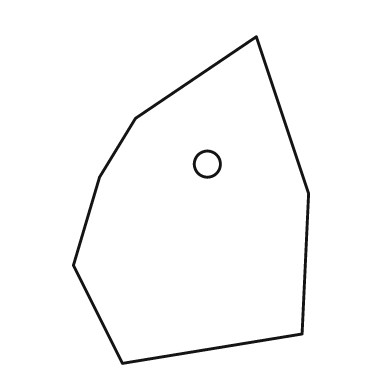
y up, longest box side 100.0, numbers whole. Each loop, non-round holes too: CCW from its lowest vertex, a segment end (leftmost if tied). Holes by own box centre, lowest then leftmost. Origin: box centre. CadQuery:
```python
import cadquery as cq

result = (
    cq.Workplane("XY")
    .moveTo(-21.0, -50.0)
    .lineTo(34.0, -41.0)
    .lineTo(36.0, 2.0)
    .lineTo(20.0, 50.0)
    .lineTo(-17.0, 25.0)
    .lineTo(-28.0, 7.0)
    .lineTo(-36.0, -20.0)
    .close()
    .moveTo(5.0, 11.0)
    .circle(4.0)
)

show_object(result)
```